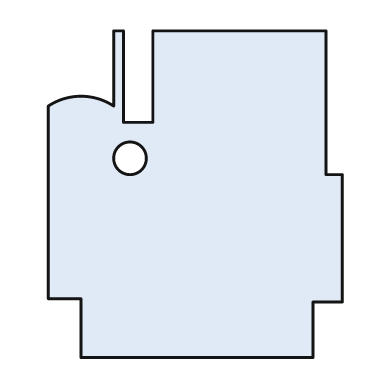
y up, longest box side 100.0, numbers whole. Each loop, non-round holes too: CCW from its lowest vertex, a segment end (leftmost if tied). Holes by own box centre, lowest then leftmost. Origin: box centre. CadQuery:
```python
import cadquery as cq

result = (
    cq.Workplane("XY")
    .moveTo(-35.0, -50.0)
    .lineTo(36.0, -50.0)
    .lineTo(36.0, -33.0)
    .lineTo(45.0, -33.0)
    .lineTo(45.0, 6.0)
    .lineTo(40.0, 6.0)
    .lineTo(40.0, 50.0)
    .lineTo(-13.0, 50.0)
    .lineTo(-13.0, 22.0)
    .lineTo(-22.0, 22.0)
    .lineTo(-22.0, 50.0)
    .lineTo(-25.0, 50.0)
    .lineTo(-25.0, 27.0)
    .threePointArc((-35.0, 30.0), (-45.0, 27.0))
    .lineTo(-45.0, -32.0)
    .lineTo(-35.0, -32.0)
    .close()
    .moveTo(-20.0, 11.0)
    .circle(5.0)
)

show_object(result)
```